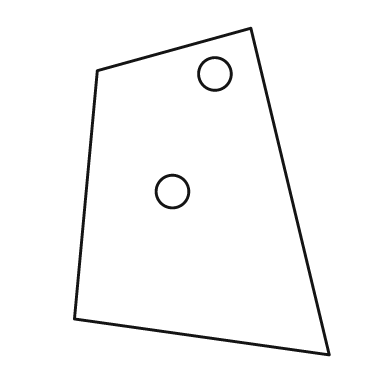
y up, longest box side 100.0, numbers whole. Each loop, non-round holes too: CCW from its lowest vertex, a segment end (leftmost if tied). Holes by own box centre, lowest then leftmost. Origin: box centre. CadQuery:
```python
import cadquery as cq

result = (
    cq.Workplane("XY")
    .moveTo(39.0, -50.0)
    .lineTo(15.0, 50.0)
    .lineTo(-32.0, 37.0)
    .lineTo(-39.0, -39.0)
    .close()
    .moveTo(-9.0, 0.0)
    .circle(5.0)
    .moveTo(4.0, 36.0)
    .circle(5.0)
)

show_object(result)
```